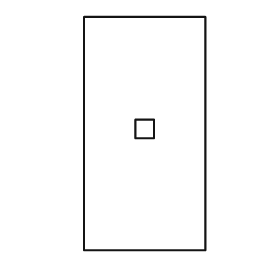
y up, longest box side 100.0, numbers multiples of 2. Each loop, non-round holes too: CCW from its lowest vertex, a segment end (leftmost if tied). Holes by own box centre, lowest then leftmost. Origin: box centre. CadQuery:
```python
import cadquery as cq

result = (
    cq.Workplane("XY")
    .moveTo(-26.0, -50.0)
    .lineTo(26.0, -50.0)
    .lineTo(26.0, 50.0)
    .lineTo(-26.0, 50.0)
    .close()
    .moveTo(-4.0, -2.0)
    .lineTo(4.0, -2.0)
    .lineTo(4.0, 6.0)
    .lineTo(-4.0, 6.0)
    .close()
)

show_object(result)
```